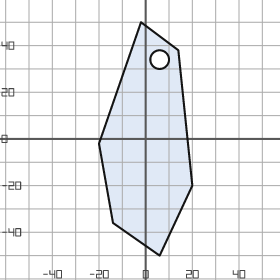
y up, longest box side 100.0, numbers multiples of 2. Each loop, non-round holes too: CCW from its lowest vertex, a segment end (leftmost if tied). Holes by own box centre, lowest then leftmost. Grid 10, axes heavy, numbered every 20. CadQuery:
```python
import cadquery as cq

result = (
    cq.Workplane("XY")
    .moveTo(6.0, -50.0)
    .lineTo(20.0, -20.0)
    .lineTo(14.0, 38.0)
    .lineTo(-2.0, 50.0)
    .lineTo(-20.0, -2.0)
    .lineTo(-14.0, -36.0)
    .close()
    .moveTo(6.0, 34.0)
    .circle(4.0)
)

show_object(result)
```